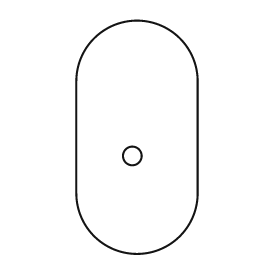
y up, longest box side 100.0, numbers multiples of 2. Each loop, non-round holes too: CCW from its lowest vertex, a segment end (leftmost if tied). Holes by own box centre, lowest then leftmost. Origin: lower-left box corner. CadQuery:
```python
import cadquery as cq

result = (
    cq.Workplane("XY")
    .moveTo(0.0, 26.0)
    .threePointArc((26.0, 0.0), (52.0, 26.0))
    .lineTo(52.0, 74.0)
    .threePointArc((26.0, 100.0), (0.0, 74.0))
    .close()
    .moveTo(24.0, 42.0)
    .circle(4.0)
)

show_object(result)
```